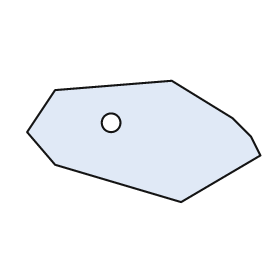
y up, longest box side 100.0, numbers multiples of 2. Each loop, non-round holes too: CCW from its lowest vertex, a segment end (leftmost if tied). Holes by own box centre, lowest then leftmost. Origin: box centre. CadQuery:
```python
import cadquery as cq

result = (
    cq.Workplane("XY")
    .moveTo(16.0, -26.0)
    .lineTo(50.0, -6.0)
    .lineTo(46.0, 2.0)
    .lineTo(38.0, 10.0)
    .lineTo(12.0, 26.0)
    .lineTo(-38.0, 22.0)
    .lineTo(-50.0, 4.0)
    .lineTo(-38.0, -10.0)
    .close()
    .moveTo(-14.0, 8.0)
    .circle(4.0)
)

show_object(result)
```